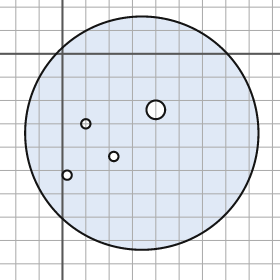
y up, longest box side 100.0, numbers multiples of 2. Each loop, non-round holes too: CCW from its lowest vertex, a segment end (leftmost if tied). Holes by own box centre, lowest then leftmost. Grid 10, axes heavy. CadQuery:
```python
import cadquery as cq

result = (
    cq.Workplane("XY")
    .moveTo(34.0, -34.0)
    .circle(50.0)
    .moveTo(2.0, -52.0)
    .circle(2.0)
    .moveTo(22.0, -44.0)
    .circle(2.0)
    .moveTo(10.0, -30.0)
    .circle(2.0)
    .moveTo(40.0, -24.0)
    .circle(4.0)
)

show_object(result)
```